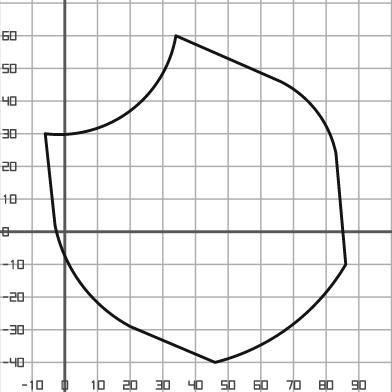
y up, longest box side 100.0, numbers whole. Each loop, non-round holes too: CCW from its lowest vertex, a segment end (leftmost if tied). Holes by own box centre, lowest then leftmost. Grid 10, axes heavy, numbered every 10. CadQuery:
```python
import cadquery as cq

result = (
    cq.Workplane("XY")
    .moveTo(46.0, -40.0)
    .threePointArc((69.0, -29.0), (86.0, -10.0))
    .lineTo(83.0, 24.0)
    .threePointArc((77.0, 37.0), (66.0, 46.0))
    .lineTo(34.0, 60.0)
    .threePointArc((20.0, 37.0), (-6.0, 30.0))
    .lineTo(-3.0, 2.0)
    .threePointArc((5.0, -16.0), (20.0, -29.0))
    .close()
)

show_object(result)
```